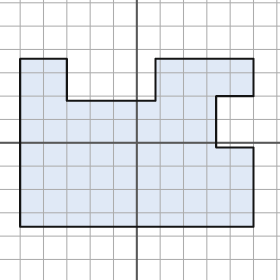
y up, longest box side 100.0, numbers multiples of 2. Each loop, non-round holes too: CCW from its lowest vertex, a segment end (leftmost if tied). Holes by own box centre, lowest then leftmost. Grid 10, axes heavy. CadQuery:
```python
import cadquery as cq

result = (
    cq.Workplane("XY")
    .moveTo(-50.0, -36.0)
    .lineTo(50.0, -36.0)
    .lineTo(50.0, -2.0)
    .lineTo(34.0, -2.0)
    .lineTo(34.0, 20.0)
    .lineTo(50.0, 20.0)
    .lineTo(50.0, 36.0)
    .lineTo(8.0, 36.0)
    .lineTo(8.0, 18.0)
    .lineTo(-30.0, 18.0)
    .lineTo(-30.0, 36.0)
    .lineTo(-50.0, 36.0)
    .close()
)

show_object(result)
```